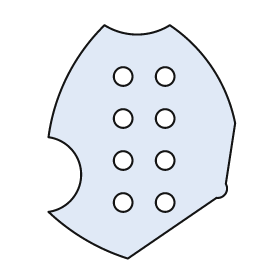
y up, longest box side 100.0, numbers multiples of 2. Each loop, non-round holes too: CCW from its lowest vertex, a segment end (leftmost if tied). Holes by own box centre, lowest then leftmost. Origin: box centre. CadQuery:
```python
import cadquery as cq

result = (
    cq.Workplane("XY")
    .moveTo(-6.0, -50.0)
    .lineTo(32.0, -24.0)
    .threePointArc((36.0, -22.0), (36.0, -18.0))
    .lineTo(40.0, 8.0)
    .threePointArc((30.0, 32.0), (12.0, 50.0))
    .threePointArc((-2.0, 46.0), (-16.0, 50.0))
    .threePointArc((-32.0, 28.0), (-40.0, 2.0))
    .threePointArc((-26.0, -14.0), (-40.0, -30.0))
    .threePointArc((-24.0, -42.0), (-6.0, -50.0))
    .close()
    .moveTo(-8.0, -26.0)
    .circle(4.0)
    .moveTo(10.0, -26.0)
    .circle(4.0)
    .moveTo(-8.0, -8.0)
    .circle(4.0)
    .moveTo(10.0, -8.0)
    .circle(4.0)
    .moveTo(-8.0, 10.0)
    .circle(4.0)
    .moveTo(10.0, 10.0)
    .circle(4.0)
    .moveTo(-8.0, 28.0)
    .circle(4.0)
    .moveTo(10.0, 28.0)
    .circle(4.0)
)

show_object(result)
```